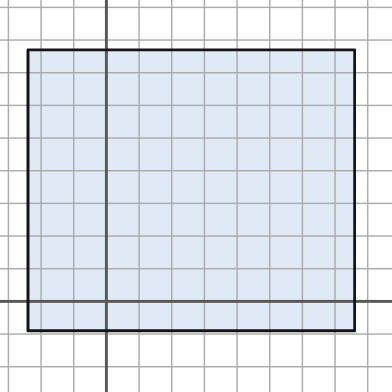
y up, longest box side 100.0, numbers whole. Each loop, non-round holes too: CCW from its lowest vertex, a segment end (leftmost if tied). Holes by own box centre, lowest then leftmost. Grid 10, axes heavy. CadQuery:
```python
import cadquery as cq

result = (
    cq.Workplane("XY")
    .moveTo(-24.0, -9.0)
    .lineTo(76.0, -9.0)
    .lineTo(76.0, 77.0)
    .lineTo(-24.0, 77.0)
    .close()
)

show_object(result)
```